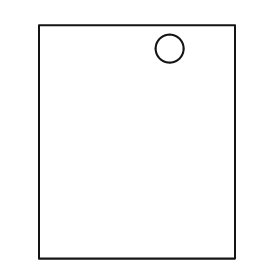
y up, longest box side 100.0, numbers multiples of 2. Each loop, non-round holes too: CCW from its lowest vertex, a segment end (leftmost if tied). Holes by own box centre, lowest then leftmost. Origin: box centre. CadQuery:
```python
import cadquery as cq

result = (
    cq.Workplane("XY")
    .moveTo(-42.0, -50.0)
    .lineTo(42.0, -50.0)
    .lineTo(42.0, 50.0)
    .lineTo(-42.0, 50.0)
    .close()
    .moveTo(14.0, 40.0)
    .circle(6.0)
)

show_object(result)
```